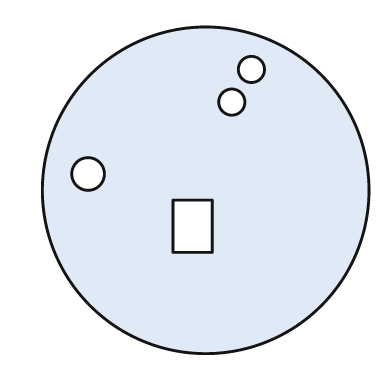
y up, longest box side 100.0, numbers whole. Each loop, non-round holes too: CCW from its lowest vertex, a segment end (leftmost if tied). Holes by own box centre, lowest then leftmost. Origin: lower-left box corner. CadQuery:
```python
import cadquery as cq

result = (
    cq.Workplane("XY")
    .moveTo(50.0, 50.0)
    .circle(50.0)
    .moveTo(40.0, 31.0)
    .lineTo(52.0, 31.0)
    .lineTo(52.0, 47.0)
    .lineTo(40.0, 47.0)
    .close()
    .moveTo(14.0, 55.0)
    .circle(5.0)
    .moveTo(58.0, 77.0)
    .circle(4.0)
    .moveTo(64.0, 87.0)
    .circle(4.0)
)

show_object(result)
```